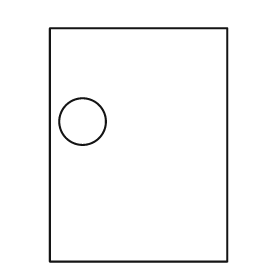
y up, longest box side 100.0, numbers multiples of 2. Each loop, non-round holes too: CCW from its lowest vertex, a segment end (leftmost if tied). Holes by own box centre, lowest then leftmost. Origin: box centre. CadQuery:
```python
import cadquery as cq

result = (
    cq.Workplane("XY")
    .moveTo(-38.0, -50.0)
    .lineTo(38.0, -50.0)
    .lineTo(38.0, 50.0)
    .lineTo(-38.0, 50.0)
    .close()
    .moveTo(-24.0, 10.0)
    .circle(10.0)
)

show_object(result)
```